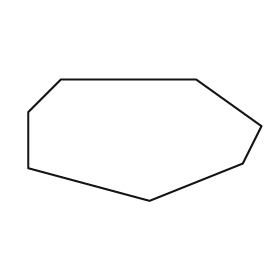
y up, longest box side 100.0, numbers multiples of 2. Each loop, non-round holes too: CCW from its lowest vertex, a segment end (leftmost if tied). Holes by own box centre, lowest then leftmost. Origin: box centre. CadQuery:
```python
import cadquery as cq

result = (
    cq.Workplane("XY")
    .moveTo(2.0, -26.0)
    .lineTo(42.0, -10.0)
    .lineTo(50.0, 6.0)
    .lineTo(22.0, 26.0)
    .lineTo(-36.0, 26.0)
    .lineTo(-50.0, 12.0)
    .lineTo(-50.0, -12.0)
    .close()
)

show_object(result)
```